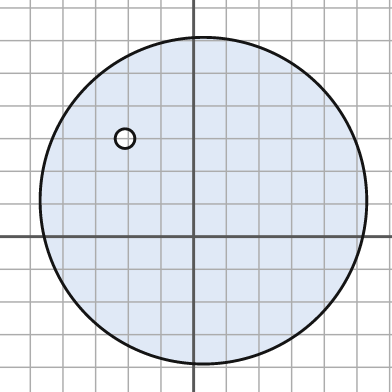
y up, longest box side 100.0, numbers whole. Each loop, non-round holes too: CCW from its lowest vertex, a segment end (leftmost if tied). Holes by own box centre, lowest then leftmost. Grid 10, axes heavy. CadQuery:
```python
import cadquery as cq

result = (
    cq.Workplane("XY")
    .moveTo(3.0, 11.0)
    .circle(50.0)
    .moveTo(-21.0, 30.0)
    .circle(3.0)
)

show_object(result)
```